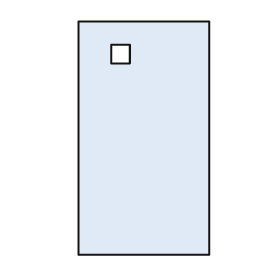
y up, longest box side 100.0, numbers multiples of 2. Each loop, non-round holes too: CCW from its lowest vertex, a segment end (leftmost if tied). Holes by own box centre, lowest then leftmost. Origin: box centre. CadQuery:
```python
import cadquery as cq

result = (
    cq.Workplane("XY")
    .moveTo(-28.0, -50.0)
    .lineTo(28.0, -50.0)
    .lineTo(28.0, 50.0)
    .lineTo(-28.0, 50.0)
    .close()
    .moveTo(-14.0, 32.0)
    .lineTo(-6.0, 32.0)
    .lineTo(-6.0, 40.0)
    .lineTo(-14.0, 40.0)
    .close()
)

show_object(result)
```